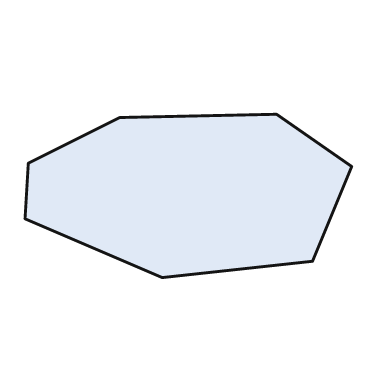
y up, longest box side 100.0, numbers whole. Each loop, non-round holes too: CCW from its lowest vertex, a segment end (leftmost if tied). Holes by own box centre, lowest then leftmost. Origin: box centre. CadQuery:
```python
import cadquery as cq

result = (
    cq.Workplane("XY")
    .moveTo(-8.0, -25.0)
    .lineTo(38.0, -20.0)
    .lineTo(50.0, 9.0)
    .lineTo(27.0, 25.0)
    .lineTo(-21.0, 24.0)
    .lineTo(-49.0, 10.0)
    .lineTo(-50.0, -7.0)
    .close()
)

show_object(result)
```